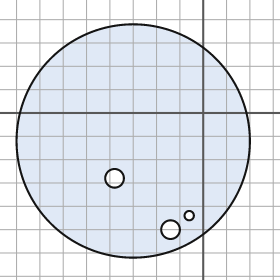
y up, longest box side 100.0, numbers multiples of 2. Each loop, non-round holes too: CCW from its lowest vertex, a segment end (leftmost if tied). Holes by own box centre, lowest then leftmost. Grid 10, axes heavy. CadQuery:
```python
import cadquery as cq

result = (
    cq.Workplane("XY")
    .moveTo(-30.0, -12.0)
    .circle(50.0)
    .moveTo(-14.0, -50.0)
    .circle(4.0)
    .moveTo(-6.0, -44.0)
    .circle(2.0)
    .moveTo(-38.0, -28.0)
    .circle(4.0)
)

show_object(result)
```